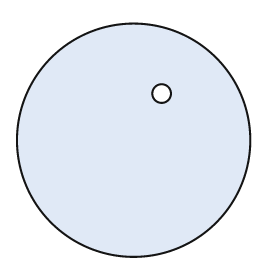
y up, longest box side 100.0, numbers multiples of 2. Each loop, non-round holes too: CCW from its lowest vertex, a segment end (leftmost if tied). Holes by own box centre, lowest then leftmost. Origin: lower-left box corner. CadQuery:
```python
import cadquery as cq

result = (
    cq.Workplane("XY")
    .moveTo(50.0, 50.0)
    .circle(50.0)
    .moveTo(62.0, 70.0)
    .circle(4.0)
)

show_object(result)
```